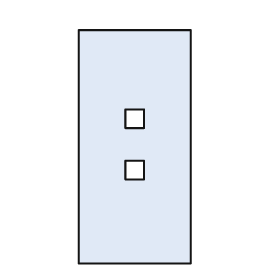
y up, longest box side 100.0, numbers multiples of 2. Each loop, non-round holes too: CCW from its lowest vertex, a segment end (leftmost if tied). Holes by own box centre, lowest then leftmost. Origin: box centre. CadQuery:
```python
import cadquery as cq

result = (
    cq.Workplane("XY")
    .moveTo(-24.0, -50.0)
    .lineTo(24.0, -50.0)
    .lineTo(24.0, 50.0)
    .lineTo(-24.0, 50.0)
    .close()
    .moveTo(-4.0, -14.0)
    .lineTo(4.0, -14.0)
    .lineTo(4.0, -6.0)
    .lineTo(-4.0, -6.0)
    .close()
    .moveTo(-4.0, 8.0)
    .lineTo(4.0, 8.0)
    .lineTo(4.0, 16.0)
    .lineTo(-4.0, 16.0)
    .close()
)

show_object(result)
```